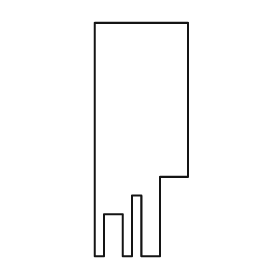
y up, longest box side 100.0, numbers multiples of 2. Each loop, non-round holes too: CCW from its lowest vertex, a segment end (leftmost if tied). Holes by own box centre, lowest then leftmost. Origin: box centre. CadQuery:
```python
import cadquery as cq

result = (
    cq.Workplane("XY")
    .moveTo(-20.0, -50.0)
    .lineTo(-16.0, -50.0)
    .lineTo(-16.0, -32.0)
    .lineTo(-8.0, -32.0)
    .lineTo(-8.0, -50.0)
    .lineTo(-4.0, -50.0)
    .lineTo(-4.0, -24.0)
    .lineTo(0.0, -24.0)
    .lineTo(0.0, -50.0)
    .lineTo(8.0, -50.0)
    .lineTo(8.0, -16.0)
    .lineTo(20.0, -16.0)
    .lineTo(20.0, 50.0)
    .lineTo(-20.0, 50.0)
    .close()
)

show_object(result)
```